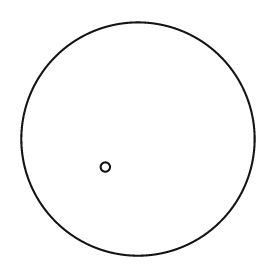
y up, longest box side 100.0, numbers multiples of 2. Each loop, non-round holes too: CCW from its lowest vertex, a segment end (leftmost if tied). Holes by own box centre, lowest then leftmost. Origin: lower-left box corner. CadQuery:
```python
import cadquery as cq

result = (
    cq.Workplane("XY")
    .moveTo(50.0, 50.0)
    .circle(50.0)
    .moveTo(36.0, 38.0)
    .circle(2.0)
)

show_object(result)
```